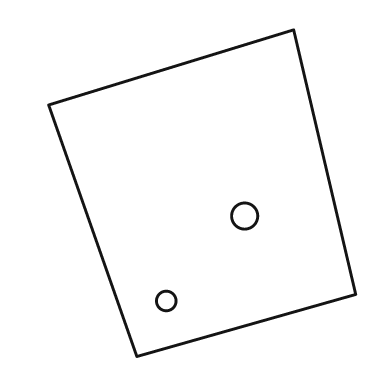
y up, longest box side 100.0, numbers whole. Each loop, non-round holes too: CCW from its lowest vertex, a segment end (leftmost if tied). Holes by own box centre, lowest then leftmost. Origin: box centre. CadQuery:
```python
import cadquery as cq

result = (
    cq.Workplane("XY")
    .moveTo(-20.0, -50.0)
    .lineTo(47.0, -31.0)
    .lineTo(28.0, 50.0)
    .lineTo(-47.0, 27.0)
    .close()
    .moveTo(-11.0, -33.0)
    .circle(3.0)
    .moveTo(13.0, -7.0)
    .circle(4.0)
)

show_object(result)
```